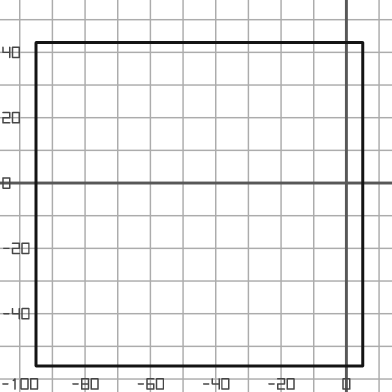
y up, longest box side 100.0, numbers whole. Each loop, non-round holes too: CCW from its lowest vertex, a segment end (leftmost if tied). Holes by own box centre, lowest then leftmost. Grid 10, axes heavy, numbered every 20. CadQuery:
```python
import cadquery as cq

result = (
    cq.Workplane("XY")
    .moveTo(-95.0, -56.0)
    .lineTo(5.0, -56.0)
    .lineTo(5.0, 43.0)
    .lineTo(-95.0, 43.0)
    .close()
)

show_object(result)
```